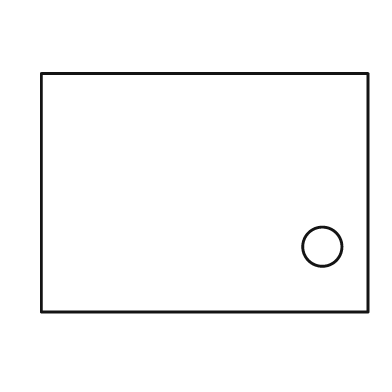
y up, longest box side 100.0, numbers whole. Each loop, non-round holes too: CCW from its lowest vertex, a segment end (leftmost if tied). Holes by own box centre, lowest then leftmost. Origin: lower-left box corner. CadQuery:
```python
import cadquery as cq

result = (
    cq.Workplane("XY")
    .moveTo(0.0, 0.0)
    .lineTo(100.0, 0.0)
    .lineTo(100.0, 73.0)
    .lineTo(0.0, 73.0)
    .close()
    .moveTo(86.0, 20.0)
    .circle(6.0)
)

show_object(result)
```